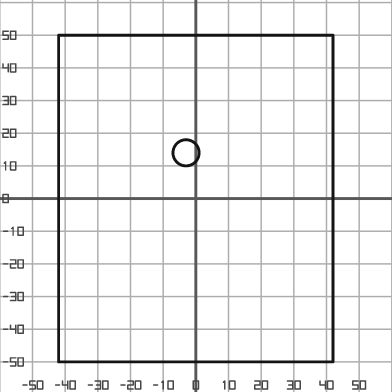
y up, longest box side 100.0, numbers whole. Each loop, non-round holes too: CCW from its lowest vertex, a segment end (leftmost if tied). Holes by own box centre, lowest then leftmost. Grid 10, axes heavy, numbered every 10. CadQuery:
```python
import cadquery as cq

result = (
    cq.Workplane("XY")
    .moveTo(-42.0, -50.0)
    .lineTo(42.0, -50.0)
    .lineTo(42.0, 50.0)
    .lineTo(-42.0, 50.0)
    .close()
    .moveTo(-3.0, 14.0)
    .circle(4.0)
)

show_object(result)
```